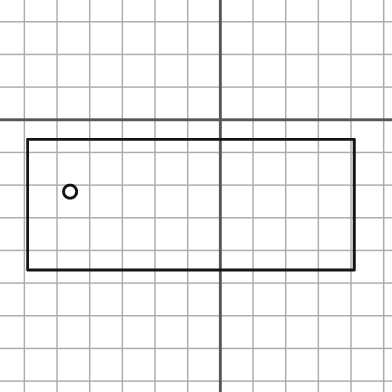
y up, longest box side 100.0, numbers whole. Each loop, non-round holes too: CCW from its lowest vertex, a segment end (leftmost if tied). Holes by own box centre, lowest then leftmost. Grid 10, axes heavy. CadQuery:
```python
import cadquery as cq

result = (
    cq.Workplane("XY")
    .moveTo(-59.0, -46.0)
    .lineTo(41.0, -46.0)
    .lineTo(41.0, -6.0)
    .lineTo(-59.0, -6.0)
    .close()
    .moveTo(-46.0, -22.0)
    .circle(2.0)
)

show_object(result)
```